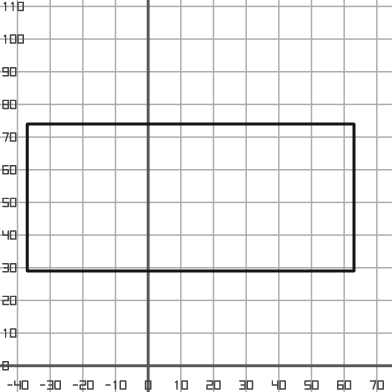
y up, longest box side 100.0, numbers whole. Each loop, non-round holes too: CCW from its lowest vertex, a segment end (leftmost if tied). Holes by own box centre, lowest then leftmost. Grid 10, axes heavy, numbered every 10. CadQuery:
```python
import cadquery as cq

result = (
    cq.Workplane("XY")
    .moveTo(-37.0, 29.0)
    .lineTo(63.0, 29.0)
    .lineTo(63.0, 74.0)
    .lineTo(-37.0, 74.0)
    .close()
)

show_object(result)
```